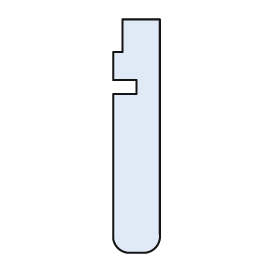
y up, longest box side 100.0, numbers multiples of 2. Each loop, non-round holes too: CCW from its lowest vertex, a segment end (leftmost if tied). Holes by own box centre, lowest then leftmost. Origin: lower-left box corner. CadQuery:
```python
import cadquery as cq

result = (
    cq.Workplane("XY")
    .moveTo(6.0, 0.0)
    .lineTo(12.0, 0.0)
    .threePointArc((18.0, 2.0), (20.0, 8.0))
    .lineTo(20.0, 100.0)
    .lineTo(4.0, 100.0)
    .lineTo(4.0, 86.0)
    .lineTo(0.0, 86.0)
    .lineTo(0.0, 74.0)
    .lineTo(10.0, 74.0)
    .lineTo(10.0, 68.0)
    .lineTo(0.0, 68.0)
    .lineTo(0.0, 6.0)
    .threePointArc((2.0, 2.0), (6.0, 0.0))
    .close()
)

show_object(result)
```